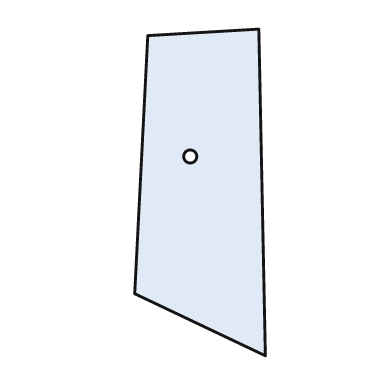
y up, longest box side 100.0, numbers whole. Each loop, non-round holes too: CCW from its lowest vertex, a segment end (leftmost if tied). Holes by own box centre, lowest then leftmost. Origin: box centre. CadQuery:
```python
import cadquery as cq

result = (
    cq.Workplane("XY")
    .moveTo(20.0, -50.0)
    .lineTo(18.0, 50.0)
    .lineTo(-16.0, 48.0)
    .lineTo(-20.0, -31.0)
    .close()
    .moveTo(-3.0, 11.0)
    .circle(2.0)
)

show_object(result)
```